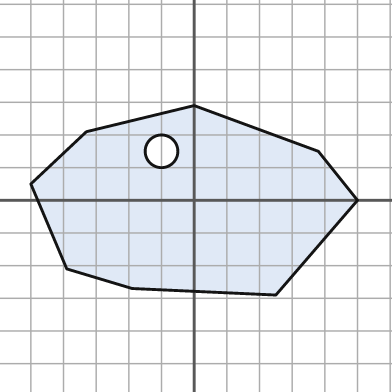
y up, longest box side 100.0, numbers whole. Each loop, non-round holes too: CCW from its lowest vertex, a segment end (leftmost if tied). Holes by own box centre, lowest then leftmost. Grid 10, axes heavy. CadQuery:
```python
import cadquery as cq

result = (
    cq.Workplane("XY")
    .moveTo(25.0, -29.0)
    .lineTo(50.0, 0.0)
    .lineTo(38.0, 15.0)
    .lineTo(0.0, 29.0)
    .lineTo(-33.0, 21.0)
    .lineTo(-50.0, 5.0)
    .lineTo(-39.0, -21.0)
    .lineTo(-19.0, -27.0)
    .close()
    .moveTo(-10.0, 15.0)
    .circle(5.0)
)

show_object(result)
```